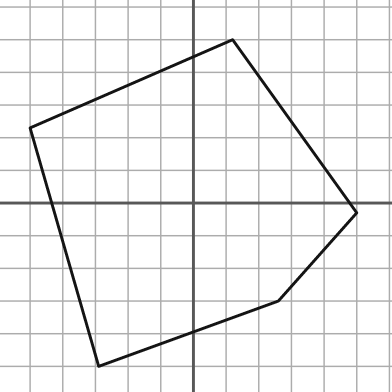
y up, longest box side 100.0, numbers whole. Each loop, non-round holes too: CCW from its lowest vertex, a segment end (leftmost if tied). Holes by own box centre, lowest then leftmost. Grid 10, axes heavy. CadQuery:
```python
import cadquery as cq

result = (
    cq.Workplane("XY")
    .moveTo(-29.0, -50.0)
    .lineTo(26.0, -30.0)
    .lineTo(50.0, -3.0)
    .lineTo(12.0, 50.0)
    .lineTo(-50.0, 23.0)
    .close()
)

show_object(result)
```